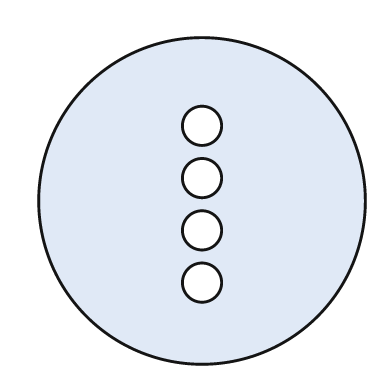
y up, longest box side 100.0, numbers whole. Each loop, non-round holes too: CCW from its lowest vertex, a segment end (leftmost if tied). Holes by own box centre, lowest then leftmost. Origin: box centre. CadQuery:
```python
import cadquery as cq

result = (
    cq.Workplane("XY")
    .moveTo(0.0, 0.0)
    .circle(50.0)
    .moveTo(0.0, -25.0)
    .circle(6.0)
    .moveTo(0.0, -9.0)
    .circle(6.0)
    .moveTo(0.0, 7.0)
    .circle(6.0)
    .moveTo(0.0, 23.0)
    .circle(6.0)
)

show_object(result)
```